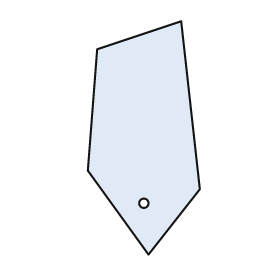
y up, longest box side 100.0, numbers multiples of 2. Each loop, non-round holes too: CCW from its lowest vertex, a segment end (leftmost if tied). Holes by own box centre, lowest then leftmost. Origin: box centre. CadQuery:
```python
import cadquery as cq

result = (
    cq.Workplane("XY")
    .moveTo(2.0, -50.0)
    .lineTo(24.0, -22.0)
    .lineTo(16.0, 50.0)
    .lineTo(-20.0, 38.0)
    .lineTo(-24.0, -14.0)
    .close()
    .moveTo(0.0, -28.0)
    .circle(2.0)
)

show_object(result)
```